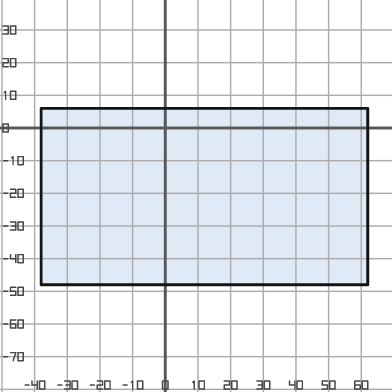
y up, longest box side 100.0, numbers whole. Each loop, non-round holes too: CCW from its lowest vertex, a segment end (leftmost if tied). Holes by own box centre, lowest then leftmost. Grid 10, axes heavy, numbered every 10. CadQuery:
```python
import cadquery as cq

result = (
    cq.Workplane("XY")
    .moveTo(-38.0, -48.0)
    .lineTo(62.0, -48.0)
    .lineTo(62.0, 6.0)
    .lineTo(-38.0, 6.0)
    .close()
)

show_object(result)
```